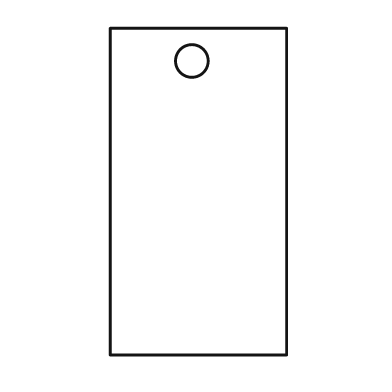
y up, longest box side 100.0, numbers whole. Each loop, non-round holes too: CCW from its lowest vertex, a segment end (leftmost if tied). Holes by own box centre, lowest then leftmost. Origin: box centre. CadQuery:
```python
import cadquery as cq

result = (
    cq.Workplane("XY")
    .moveTo(-27.0, -50.0)
    .lineTo(27.0, -50.0)
    .lineTo(27.0, 50.0)
    .lineTo(-27.0, 50.0)
    .close()
    .moveTo(-2.0, 40.0)
    .circle(5.0)
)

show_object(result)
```